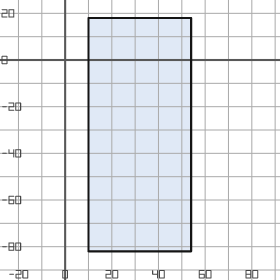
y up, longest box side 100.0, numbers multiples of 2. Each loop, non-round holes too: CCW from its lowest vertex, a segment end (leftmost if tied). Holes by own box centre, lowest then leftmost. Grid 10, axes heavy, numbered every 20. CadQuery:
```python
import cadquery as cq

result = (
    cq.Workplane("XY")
    .moveTo(10.0, -82.0)
    .lineTo(54.0, -82.0)
    .lineTo(54.0, 18.0)
    .lineTo(10.0, 18.0)
    .close()
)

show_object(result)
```